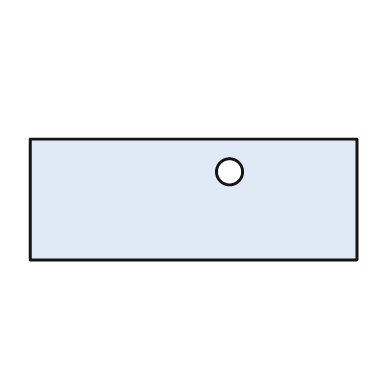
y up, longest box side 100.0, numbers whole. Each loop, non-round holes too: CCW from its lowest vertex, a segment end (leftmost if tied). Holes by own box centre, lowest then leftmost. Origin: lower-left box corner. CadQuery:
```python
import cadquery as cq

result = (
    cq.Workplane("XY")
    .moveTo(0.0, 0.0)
    .lineTo(100.0, 0.0)
    .lineTo(100.0, 37.0)
    .lineTo(0.0, 37.0)
    .close()
    .moveTo(61.0, 27.0)
    .circle(4.0)
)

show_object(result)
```